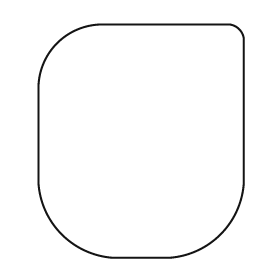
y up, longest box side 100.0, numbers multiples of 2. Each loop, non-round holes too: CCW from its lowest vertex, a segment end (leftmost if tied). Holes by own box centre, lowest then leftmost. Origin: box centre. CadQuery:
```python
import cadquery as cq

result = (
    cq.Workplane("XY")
    .moveTo(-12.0, -50.0)
    .lineTo(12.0, -50.0)
    .threePointArc((34.0, -40.0), (44.0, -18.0))
    .lineTo(44.0, 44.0)
    .threePointArc((42.0, 48.0), (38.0, 50.0))
    .lineTo(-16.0, 50.0)
    .threePointArc((-36.0, 42.0), (-44.0, 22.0))
    .lineTo(-44.0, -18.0)
    .threePointArc((-34.0, -40.0), (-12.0, -50.0))
    .close()
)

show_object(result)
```